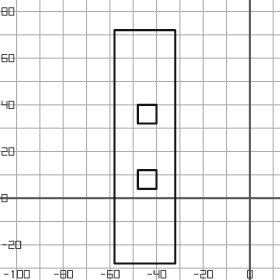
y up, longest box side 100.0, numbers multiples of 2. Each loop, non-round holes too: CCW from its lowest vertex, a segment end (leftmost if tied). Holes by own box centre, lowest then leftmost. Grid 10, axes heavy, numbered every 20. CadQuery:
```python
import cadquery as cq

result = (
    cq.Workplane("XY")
    .moveTo(-58.0, -28.0)
    .lineTo(-32.0, -28.0)
    .lineTo(-32.0, 72.0)
    .lineTo(-58.0, 72.0)
    .close()
    .moveTo(-48.0, 4.0)
    .lineTo(-40.0, 4.0)
    .lineTo(-40.0, 12.0)
    .lineTo(-48.0, 12.0)
    .close()
    .moveTo(-48.0, 32.0)
    .lineTo(-40.0, 32.0)
    .lineTo(-40.0, 40.0)
    .lineTo(-48.0, 40.0)
    .close()
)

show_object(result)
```